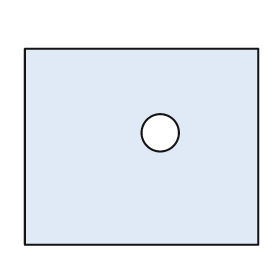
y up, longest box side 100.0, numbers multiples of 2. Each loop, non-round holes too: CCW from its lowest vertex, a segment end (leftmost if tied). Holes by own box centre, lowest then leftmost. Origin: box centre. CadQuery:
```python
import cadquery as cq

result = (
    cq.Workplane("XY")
    .moveTo(-50.0, -42.0)
    .lineTo(50.0, -42.0)
    .lineTo(50.0, 42.0)
    .lineTo(-50.0, 42.0)
    .close()
    .moveTo(8.0, 6.0)
    .circle(8.0)
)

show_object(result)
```